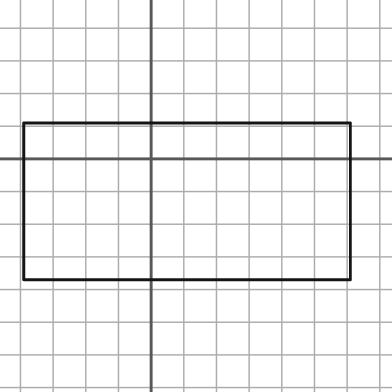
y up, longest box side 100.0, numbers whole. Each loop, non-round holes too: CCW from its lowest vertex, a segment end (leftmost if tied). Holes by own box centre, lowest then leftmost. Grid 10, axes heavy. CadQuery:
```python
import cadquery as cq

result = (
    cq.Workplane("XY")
    .moveTo(-39.0, -37.0)
    .lineTo(61.0, -37.0)
    .lineTo(61.0, 11.0)
    .lineTo(-39.0, 11.0)
    .close()
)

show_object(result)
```